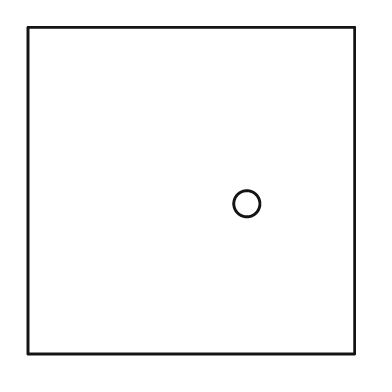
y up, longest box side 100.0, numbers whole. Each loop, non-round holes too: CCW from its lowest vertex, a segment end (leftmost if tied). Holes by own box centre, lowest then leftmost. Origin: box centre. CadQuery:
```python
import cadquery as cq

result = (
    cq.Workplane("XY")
    .moveTo(-50.0, -50.0)
    .lineTo(50.0, -50.0)
    .lineTo(50.0, 50.0)
    .lineTo(-50.0, 50.0)
    .close()
    .moveTo(17.0, -4.0)
    .circle(4.0)
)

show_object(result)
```